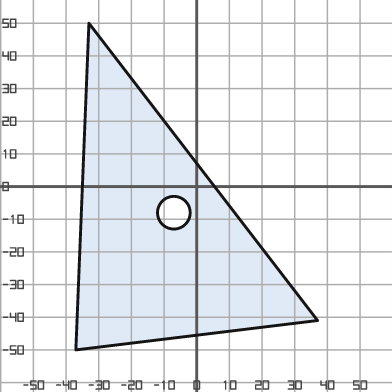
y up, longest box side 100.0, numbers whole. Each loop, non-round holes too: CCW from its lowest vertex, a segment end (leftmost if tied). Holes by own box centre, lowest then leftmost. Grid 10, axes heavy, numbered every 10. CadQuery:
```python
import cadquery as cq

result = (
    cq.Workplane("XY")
    .moveTo(-37.0, -50.0)
    .lineTo(37.0, -41.0)
    .lineTo(-33.0, 50.0)
    .close()
    .moveTo(-7.0, -8.0)
    .circle(5.0)
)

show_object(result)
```